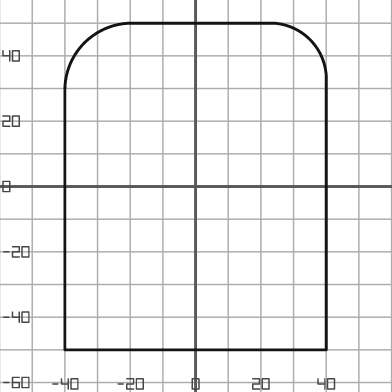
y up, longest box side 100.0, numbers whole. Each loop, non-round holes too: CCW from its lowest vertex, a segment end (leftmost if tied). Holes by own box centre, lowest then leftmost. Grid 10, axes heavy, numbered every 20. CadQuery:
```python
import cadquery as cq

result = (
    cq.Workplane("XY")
    .moveTo(-40.0, -50.0)
    .lineTo(40.0, -50.0)
    .lineTo(40.0, 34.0)
    .threePointArc((35.0, 45.0), (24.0, 50.0))
    .lineTo(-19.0, 50.0)
    .threePointArc((-34.0, 44.0), (-40.0, 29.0))
    .close()
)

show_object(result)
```